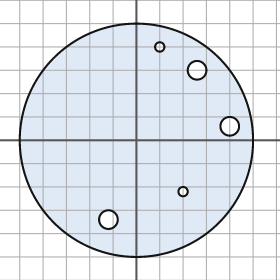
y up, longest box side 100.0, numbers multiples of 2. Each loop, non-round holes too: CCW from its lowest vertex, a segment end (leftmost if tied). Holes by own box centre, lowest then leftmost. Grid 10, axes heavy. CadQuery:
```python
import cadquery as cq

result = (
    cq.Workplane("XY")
    .moveTo(0.0, 0.0)
    .circle(50.0)
    .moveTo(-12.0, -34.0)
    .circle(4.0)
    .moveTo(20.0, -22.0)
    .circle(2.0)
    .moveTo(40.0, 6.0)
    .circle(4.0)
    .moveTo(26.0, 30.0)
    .circle(4.0)
    .moveTo(10.0, 40.0)
    .circle(2.0)
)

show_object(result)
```